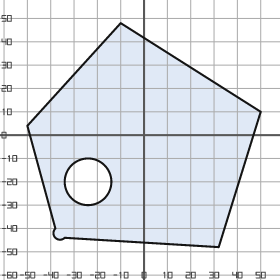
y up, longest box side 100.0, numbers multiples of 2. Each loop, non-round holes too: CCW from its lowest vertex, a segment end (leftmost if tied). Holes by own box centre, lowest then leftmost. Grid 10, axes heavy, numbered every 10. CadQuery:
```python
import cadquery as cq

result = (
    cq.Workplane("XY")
    .moveTo(32.0, -48.0)
    .lineTo(50.0, 10.0)
    .lineTo(-10.0, 48.0)
    .lineTo(-50.0, 4.0)
    .lineTo(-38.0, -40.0)
    .threePointArc((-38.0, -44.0), (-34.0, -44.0))
    .close()
    .moveTo(-24.0, -20.0)
    .circle(10.0)
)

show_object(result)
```